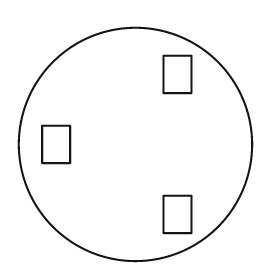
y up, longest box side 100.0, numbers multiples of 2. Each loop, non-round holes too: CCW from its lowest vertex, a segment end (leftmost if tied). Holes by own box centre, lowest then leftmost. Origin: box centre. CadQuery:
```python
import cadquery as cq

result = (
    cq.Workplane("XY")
    .moveTo(0.0, 0.0)
    .circle(50.0)
    .moveTo(12.0, -38.0)
    .lineTo(24.0, -38.0)
    .lineTo(24.0, -22.0)
    .lineTo(12.0, -22.0)
    .close()
    .moveTo(-40.0, -8.0)
    .lineTo(-28.0, -8.0)
    .lineTo(-28.0, 8.0)
    .lineTo(-40.0, 8.0)
    .close()
    .moveTo(12.0, 22.0)
    .lineTo(24.0, 22.0)
    .lineTo(24.0, 38.0)
    .lineTo(12.0, 38.0)
    .close()
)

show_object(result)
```